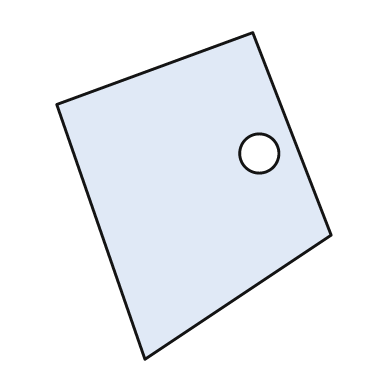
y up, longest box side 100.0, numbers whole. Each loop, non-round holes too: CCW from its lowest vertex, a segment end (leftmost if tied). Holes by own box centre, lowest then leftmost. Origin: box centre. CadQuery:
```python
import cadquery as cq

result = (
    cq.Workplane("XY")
    .moveTo(-15.0, -50.0)
    .lineTo(42.0, -12.0)
    .lineTo(18.0, 50.0)
    .lineTo(-42.0, 28.0)
    .close()
    .moveTo(20.0, 13.0)
    .circle(6.0)
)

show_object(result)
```